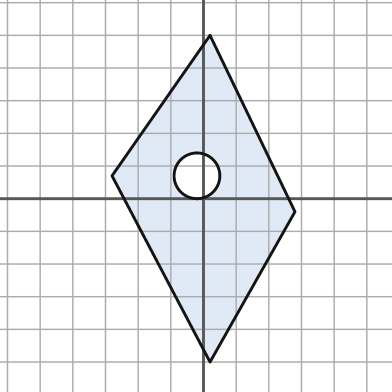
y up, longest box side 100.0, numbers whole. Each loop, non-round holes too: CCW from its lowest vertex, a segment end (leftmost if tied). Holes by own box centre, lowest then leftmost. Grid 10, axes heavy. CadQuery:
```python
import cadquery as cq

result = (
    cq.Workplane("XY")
    .moveTo(2.0, -50.0)
    .lineTo(28.0, -4.0)
    .lineTo(2.0, 50.0)
    .lineTo(-28.0, 7.0)
    .close()
    .moveTo(-2.0, 7.0)
    .circle(7.0)
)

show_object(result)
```